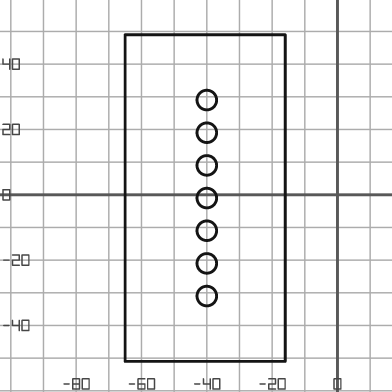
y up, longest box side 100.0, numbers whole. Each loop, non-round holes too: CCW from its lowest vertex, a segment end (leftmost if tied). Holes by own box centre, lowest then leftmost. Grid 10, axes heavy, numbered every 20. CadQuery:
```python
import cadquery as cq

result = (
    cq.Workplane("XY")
    .moveTo(-65.0, -51.0)
    .lineTo(-16.0, -51.0)
    .lineTo(-16.0, 49.0)
    .lineTo(-65.0, 49.0)
    .close()
    .moveTo(-40.0, -31.0)
    .circle(3.0)
    .moveTo(-40.0, -21.0)
    .circle(3.0)
    .moveTo(-40.0, -11.0)
    .circle(3.0)
    .moveTo(-40.0, -1.0)
    .circle(3.0)
    .moveTo(-40.0, 9.0)
    .circle(3.0)
    .moveTo(-40.0, 19.0)
    .circle(3.0)
    .moveTo(-40.0, 29.0)
    .circle(3.0)
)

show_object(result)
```